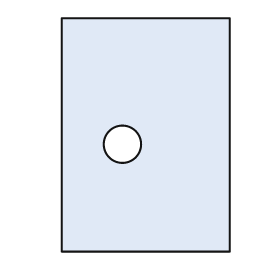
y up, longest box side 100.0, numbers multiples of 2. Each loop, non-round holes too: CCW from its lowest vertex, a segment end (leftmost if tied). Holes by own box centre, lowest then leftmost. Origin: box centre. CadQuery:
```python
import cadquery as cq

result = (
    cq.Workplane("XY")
    .moveTo(-36.0, -50.0)
    .lineTo(36.0, -50.0)
    .lineTo(36.0, 50.0)
    .lineTo(-36.0, 50.0)
    .close()
    .moveTo(-10.0, -4.0)
    .circle(8.0)
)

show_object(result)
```